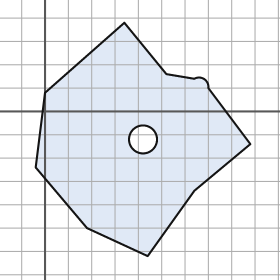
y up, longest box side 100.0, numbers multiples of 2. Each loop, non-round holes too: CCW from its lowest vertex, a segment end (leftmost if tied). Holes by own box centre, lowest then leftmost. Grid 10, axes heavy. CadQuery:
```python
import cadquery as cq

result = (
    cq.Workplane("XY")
    .moveTo(44.0, -62.0)
    .lineTo(64.0, -34.0)
    .lineTo(88.0, -14.0)
    .lineTo(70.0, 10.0)
    .threePointArc((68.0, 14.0), (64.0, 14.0))
    .lineTo(52.0, 16.0)
    .lineTo(34.0, 38.0)
    .lineTo(0.0, 8.0)
    .lineTo(-4.0, -24.0)
    .lineTo(18.0, -50.0)
    .close()
    .moveTo(42.0, -12.0)
    .circle(6.0)
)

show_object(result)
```